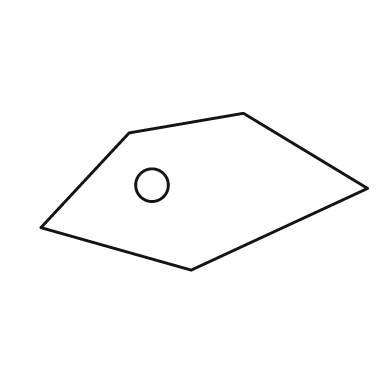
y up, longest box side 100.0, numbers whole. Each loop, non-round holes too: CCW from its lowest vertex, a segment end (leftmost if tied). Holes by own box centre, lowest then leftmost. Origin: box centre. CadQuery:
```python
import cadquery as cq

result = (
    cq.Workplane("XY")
    .moveTo(-4.0, -24.0)
    .lineTo(50.0, 1.0)
    .lineTo(12.0, 24.0)
    .lineTo(-23.0, 18.0)
    .lineTo(-50.0, -11.0)
    .close()
    .moveTo(-16.0, 2.0)
    .circle(5.0)
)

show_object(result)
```